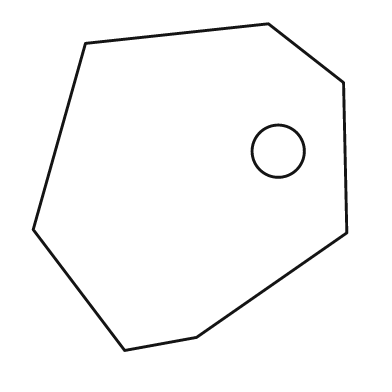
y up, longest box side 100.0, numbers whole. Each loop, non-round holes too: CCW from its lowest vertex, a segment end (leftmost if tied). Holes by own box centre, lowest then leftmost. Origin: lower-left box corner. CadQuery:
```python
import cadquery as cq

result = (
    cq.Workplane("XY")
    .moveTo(28.0, 0.0)
    .lineTo(50.0, 4.0)
    .lineTo(96.0, 36.0)
    .lineTo(95.0, 82.0)
    .lineTo(72.0, 100.0)
    .lineTo(16.0, 94.0)
    .lineTo(0.0, 37.0)
    .close()
    .moveTo(75.0, 61.0)
    .circle(8.0)
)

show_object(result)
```